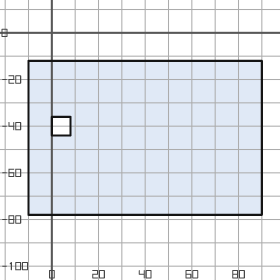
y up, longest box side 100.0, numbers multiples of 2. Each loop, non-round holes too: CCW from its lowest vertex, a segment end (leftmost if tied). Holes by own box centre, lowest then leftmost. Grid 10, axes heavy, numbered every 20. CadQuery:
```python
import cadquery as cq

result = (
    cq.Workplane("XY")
    .moveTo(-10.0, -78.0)
    .lineTo(90.0, -78.0)
    .lineTo(90.0, -12.0)
    .lineTo(-10.0, -12.0)
    .close()
    .moveTo(0.0, -44.0)
    .lineTo(8.0, -44.0)
    .lineTo(8.0, -36.0)
    .lineTo(0.0, -36.0)
    .close()
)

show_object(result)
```